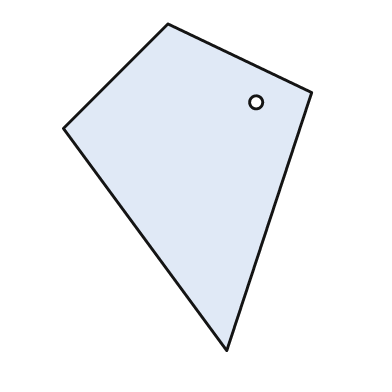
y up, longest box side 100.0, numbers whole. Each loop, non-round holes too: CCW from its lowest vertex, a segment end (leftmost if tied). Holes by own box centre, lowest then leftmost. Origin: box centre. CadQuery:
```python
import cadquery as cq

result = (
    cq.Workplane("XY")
    .moveTo(12.0, -50.0)
    .lineTo(38.0, 29.0)
    .lineTo(-6.0, 50.0)
    .lineTo(-38.0, 18.0)
    .close()
    .moveTo(21.0, 26.0)
    .circle(2.0)
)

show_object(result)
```